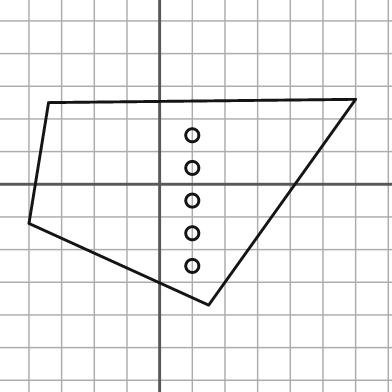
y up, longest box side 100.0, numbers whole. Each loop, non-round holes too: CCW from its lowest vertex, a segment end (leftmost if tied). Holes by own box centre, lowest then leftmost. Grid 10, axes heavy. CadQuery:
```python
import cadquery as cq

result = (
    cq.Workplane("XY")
    .moveTo(15.0, -37.0)
    .lineTo(60.0, 26.0)
    .lineTo(-34.0, 25.0)
    .lineTo(-40.0, -12.0)
    .close()
    .moveTo(10.0, -25.0)
    .circle(2.0)
    .moveTo(10.0, -15.0)
    .circle(2.0)
    .moveTo(10.0, -5.0)
    .circle(2.0)
    .moveTo(10.0, 5.0)
    .circle(2.0)
    .moveTo(10.0, 15.0)
    .circle(2.0)
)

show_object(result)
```